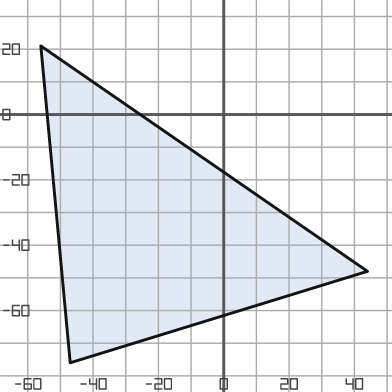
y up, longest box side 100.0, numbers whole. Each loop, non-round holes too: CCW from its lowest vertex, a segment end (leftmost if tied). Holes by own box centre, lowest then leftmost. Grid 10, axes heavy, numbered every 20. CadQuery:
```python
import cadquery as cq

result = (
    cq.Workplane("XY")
    .moveTo(-47.0, -76.0)
    .lineTo(44.0, -48.0)
    .lineTo(-56.0, 21.0)
    .close()
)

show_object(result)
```